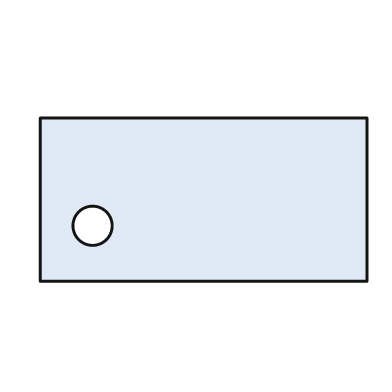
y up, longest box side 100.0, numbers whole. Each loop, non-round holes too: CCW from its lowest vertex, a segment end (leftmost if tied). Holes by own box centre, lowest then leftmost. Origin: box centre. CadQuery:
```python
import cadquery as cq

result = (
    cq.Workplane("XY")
    .moveTo(-50.0, -25.0)
    .lineTo(50.0, -25.0)
    .lineTo(50.0, 25.0)
    .lineTo(-50.0, 25.0)
    .close()
    .moveTo(-34.0, -8.0)
    .circle(6.0)
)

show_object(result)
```